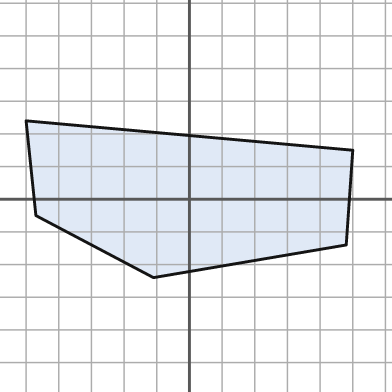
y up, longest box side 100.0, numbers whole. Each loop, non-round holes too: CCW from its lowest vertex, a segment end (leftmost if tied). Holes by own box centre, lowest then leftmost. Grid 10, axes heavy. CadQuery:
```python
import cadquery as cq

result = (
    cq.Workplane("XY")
    .moveTo(-11.0, -24.0)
    .lineTo(48.0, -14.0)
    .lineTo(50.0, 15.0)
    .lineTo(-50.0, 24.0)
    .lineTo(-47.0, -5.0)
    .close()
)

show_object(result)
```